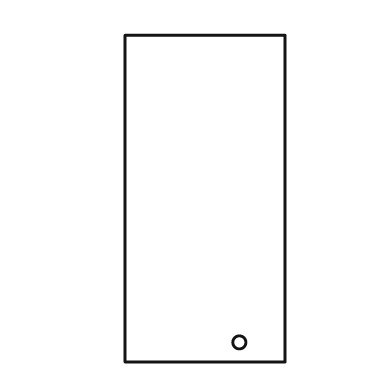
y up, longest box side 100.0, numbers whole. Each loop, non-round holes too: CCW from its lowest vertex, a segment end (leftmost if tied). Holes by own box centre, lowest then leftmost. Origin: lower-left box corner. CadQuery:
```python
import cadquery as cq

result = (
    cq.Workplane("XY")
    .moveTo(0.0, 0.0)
    .lineTo(49.0, 0.0)
    .lineTo(49.0, 100.0)
    .lineTo(0.0, 100.0)
    .close()
    .moveTo(35.0, 6.0)
    .circle(2.0)
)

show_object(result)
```